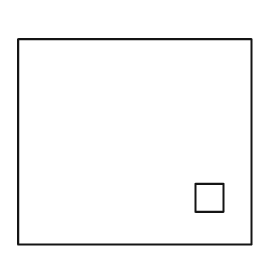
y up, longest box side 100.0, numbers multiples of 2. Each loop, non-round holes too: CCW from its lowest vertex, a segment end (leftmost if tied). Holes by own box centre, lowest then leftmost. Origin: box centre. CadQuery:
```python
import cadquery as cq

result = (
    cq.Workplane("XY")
    .moveTo(-50.0, -44.0)
    .lineTo(50.0, -44.0)
    .lineTo(50.0, 44.0)
    .lineTo(-50.0, 44.0)
    .close()
    .moveTo(26.0, -30.0)
    .lineTo(38.0, -30.0)
    .lineTo(38.0, -18.0)
    .lineTo(26.0, -18.0)
    .close()
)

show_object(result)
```